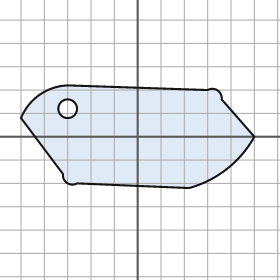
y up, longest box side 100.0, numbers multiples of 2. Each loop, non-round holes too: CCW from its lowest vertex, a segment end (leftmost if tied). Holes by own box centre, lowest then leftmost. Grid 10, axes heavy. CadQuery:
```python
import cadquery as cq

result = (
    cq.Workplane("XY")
    .moveTo(22.0, -22.0)
    .threePointArc((38.0, -14.0), (50.0, 0.0))
    .lineTo(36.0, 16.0)
    .threePointArc((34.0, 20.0), (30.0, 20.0))
    .lineTo(-30.0, 22.0)
    .threePointArc((-42.0, 18.0), (-50.0, 8.0))
    .lineTo(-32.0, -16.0)
    .threePointArc((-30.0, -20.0), (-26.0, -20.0))
    .close()
    .moveTo(-30.0, 12.0)
    .circle(4.0)
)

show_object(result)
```